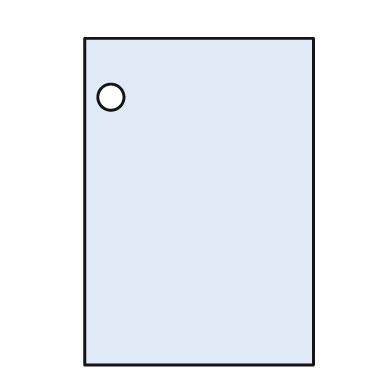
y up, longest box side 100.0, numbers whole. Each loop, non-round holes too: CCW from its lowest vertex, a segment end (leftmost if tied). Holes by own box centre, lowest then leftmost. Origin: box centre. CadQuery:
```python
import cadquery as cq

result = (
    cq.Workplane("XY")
    .moveTo(-35.0, -50.0)
    .lineTo(35.0, -50.0)
    .lineTo(35.0, 50.0)
    .lineTo(-35.0, 50.0)
    .close()
    .moveTo(-27.0, 32.0)
    .circle(4.0)
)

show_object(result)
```